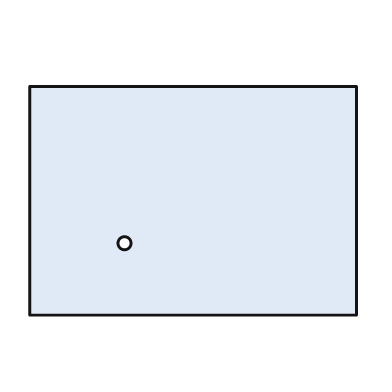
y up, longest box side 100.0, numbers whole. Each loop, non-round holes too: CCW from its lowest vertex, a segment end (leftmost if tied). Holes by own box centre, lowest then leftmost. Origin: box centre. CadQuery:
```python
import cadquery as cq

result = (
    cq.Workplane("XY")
    .moveTo(-50.0, -35.0)
    .lineTo(50.0, -35.0)
    .lineTo(50.0, 35.0)
    .lineTo(-50.0, 35.0)
    .close()
    .moveTo(-21.0, -13.0)
    .circle(2.0)
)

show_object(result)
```